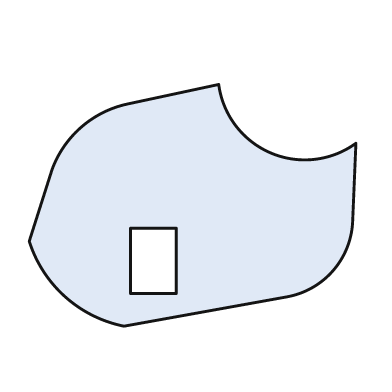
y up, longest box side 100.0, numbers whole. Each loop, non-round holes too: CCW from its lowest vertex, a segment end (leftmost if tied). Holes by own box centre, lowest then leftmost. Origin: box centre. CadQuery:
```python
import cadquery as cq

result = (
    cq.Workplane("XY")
    .moveTo(-21.0, -37.0)
    .lineTo(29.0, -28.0)
    .threePointArc((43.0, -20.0), (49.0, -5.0))
    .lineTo(50.0, 19.0)
    .threePointArc((24.0, 16.0), (8.0, 37.0))
    .lineTo(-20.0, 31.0)
    .threePointArc((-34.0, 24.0), (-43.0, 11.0))
    .lineTo(-50.0, -11.0)
    .threePointArc((-39.0, -28.0), (-21.0, -37.0))
    .close()
    .moveTo(-19.0, -27.0)
    .lineTo(-5.0, -27.0)
    .lineTo(-5.0, -7.0)
    .lineTo(-19.0, -7.0)
    .close()
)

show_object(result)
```